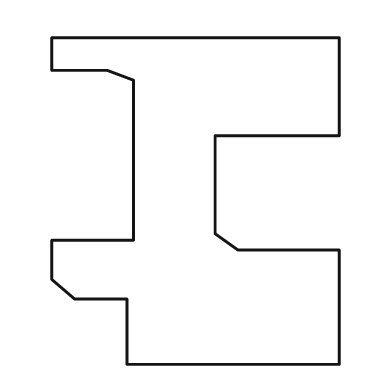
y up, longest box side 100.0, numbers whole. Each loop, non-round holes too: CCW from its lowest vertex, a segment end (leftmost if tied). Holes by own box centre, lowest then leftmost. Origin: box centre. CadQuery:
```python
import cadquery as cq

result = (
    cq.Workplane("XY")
    .moveTo(-21.0, -50.0)
    .lineTo(44.0, -50.0)
    .lineTo(44.0, -15.0)
    .lineTo(13.0, -15.0)
    .lineTo(6.0, -10.0)
    .lineTo(6.0, 20.0)
    .lineTo(44.0, 20.0)
    .lineTo(44.0, 50.0)
    .lineTo(-44.0, 50.0)
    .lineTo(-44.0, 40.0)
    .lineTo(-27.0, 40.0)
    .lineTo(-19.0, 37.0)
    .lineTo(-19.0, -12.0)
    .lineTo(-44.0, -12.0)
    .lineTo(-44.0, -24.0)
    .lineTo(-37.0, -30.0)
    .lineTo(-21.0, -30.0)
    .close()
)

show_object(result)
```